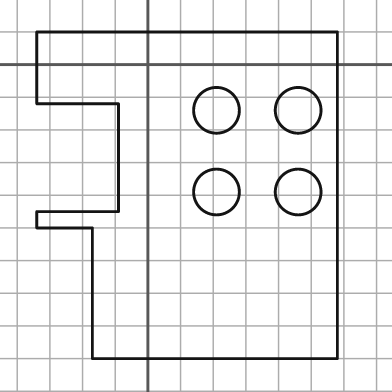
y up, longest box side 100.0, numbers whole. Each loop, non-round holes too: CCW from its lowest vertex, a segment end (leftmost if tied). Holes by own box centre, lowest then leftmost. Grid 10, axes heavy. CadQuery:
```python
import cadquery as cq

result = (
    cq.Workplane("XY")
    .moveTo(-17.0, -90.0)
    .lineTo(58.0, -90.0)
    .lineTo(58.0, 10.0)
    .lineTo(-34.0, 10.0)
    .lineTo(-34.0, -12.0)
    .lineTo(-9.0, -12.0)
    .lineTo(-9.0, -45.0)
    .lineTo(-34.0, -45.0)
    .lineTo(-34.0, -50.0)
    .lineTo(-17.0, -50.0)
    .close()
    .moveTo(21.0, -39.0)
    .circle(7.0)
    .moveTo(46.0, -39.0)
    .circle(7.0)
    .moveTo(21.0, -14.0)
    .circle(7.0)
    .moveTo(46.0, -14.0)
    .circle(7.0)
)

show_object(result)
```